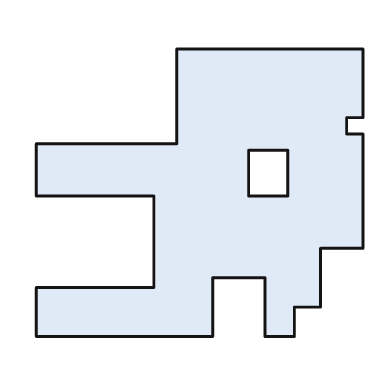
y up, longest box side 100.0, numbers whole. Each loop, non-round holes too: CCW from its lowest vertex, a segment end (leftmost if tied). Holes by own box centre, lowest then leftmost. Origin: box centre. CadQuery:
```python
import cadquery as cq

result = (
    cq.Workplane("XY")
    .moveTo(-50.0, -44.0)
    .lineTo(4.0, -44.0)
    .lineTo(4.0, -26.0)
    .lineTo(20.0, -26.0)
    .lineTo(20.0, -44.0)
    .lineTo(29.0, -44.0)
    .lineTo(29.0, -35.0)
    .lineTo(37.0, -35.0)
    .lineTo(37.0, -17.0)
    .lineTo(50.0, -17.0)
    .lineTo(50.0, 18.0)
    .lineTo(45.0, 18.0)
    .lineTo(45.0, 23.0)
    .lineTo(50.0, 23.0)
    .lineTo(50.0, 44.0)
    .lineTo(-7.0, 44.0)
    .lineTo(-7.0, 15.0)
    .lineTo(-50.0, 15.0)
    .lineTo(-50.0, -1.0)
    .lineTo(-14.0, -1.0)
    .lineTo(-14.0, -29.0)
    .lineTo(-50.0, -29.0)
    .close()
    .moveTo(15.0, -1.0)
    .lineTo(27.0, -1.0)
    .lineTo(27.0, 13.0)
    .lineTo(15.0, 13.0)
    .close()
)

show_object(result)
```